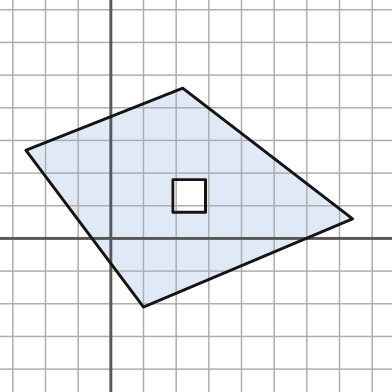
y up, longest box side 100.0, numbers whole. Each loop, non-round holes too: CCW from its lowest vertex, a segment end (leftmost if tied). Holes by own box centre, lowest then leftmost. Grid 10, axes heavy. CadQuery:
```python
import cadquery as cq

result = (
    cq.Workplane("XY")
    .moveTo(10.0, -21.0)
    .lineTo(74.0, 6.0)
    .lineTo(22.0, 46.0)
    .lineTo(-26.0, 27.0)
    .close()
    .moveTo(19.0, 8.0)
    .lineTo(29.0, 8.0)
    .lineTo(29.0, 18.0)
    .lineTo(19.0, 18.0)
    .close()
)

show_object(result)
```